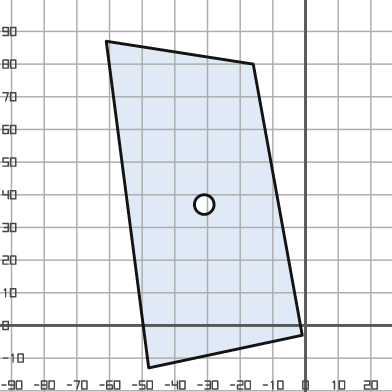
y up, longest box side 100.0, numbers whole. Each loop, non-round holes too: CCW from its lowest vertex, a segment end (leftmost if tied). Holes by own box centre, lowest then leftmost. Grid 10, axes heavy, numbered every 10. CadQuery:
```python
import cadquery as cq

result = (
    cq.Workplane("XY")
    .moveTo(-48.0, -13.0)
    .lineTo(-1.0, -3.0)
    .lineTo(-16.0, 80.0)
    .lineTo(-61.0, 87.0)
    .close()
    .moveTo(-31.0, 37.0)
    .circle(3.0)
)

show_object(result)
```